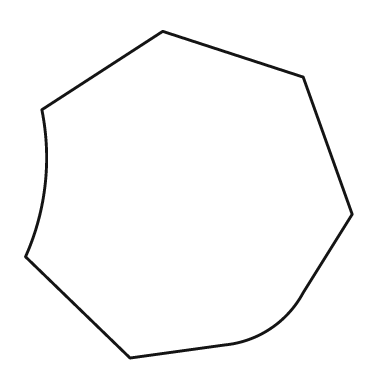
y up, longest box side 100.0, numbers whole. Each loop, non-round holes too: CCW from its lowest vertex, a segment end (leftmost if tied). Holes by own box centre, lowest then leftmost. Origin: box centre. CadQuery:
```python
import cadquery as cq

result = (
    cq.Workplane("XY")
    .moveTo(-18.0, -50.0)
    .lineTo(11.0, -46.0)
    .threePointArc((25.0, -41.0), (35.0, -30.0))
    .lineTo(50.0, -6.0)
    .lineTo(35.0, 36.0)
    .lineTo(-8.0, 50.0)
    .lineTo(-45.0, 26.0)
    .threePointArc((-44.0, 3.0), (-50.0, -19.0))
    .close()
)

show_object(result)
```